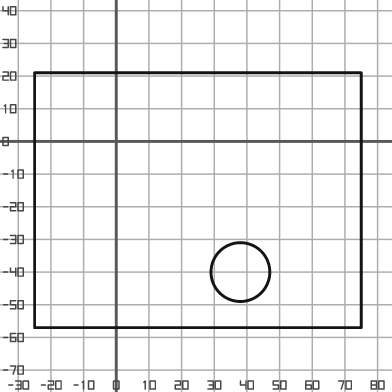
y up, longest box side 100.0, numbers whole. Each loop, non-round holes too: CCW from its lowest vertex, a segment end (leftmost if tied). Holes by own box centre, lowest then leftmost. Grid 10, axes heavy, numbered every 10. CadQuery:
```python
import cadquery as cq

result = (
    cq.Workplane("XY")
    .moveTo(-25.0, -57.0)
    .lineTo(75.0, -57.0)
    .lineTo(75.0, 21.0)
    .lineTo(-25.0, 21.0)
    .close()
    .moveTo(38.0, -40.0)
    .circle(9.0)
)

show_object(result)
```